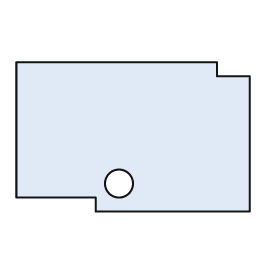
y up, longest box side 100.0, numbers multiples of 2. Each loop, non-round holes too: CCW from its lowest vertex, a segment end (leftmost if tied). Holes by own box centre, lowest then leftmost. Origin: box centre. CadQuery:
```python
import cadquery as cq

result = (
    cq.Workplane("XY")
    .moveTo(-16.0, -32.0)
    .lineTo(50.0, -32.0)
    .lineTo(50.0, 26.0)
    .lineTo(36.0, 26.0)
    .lineTo(36.0, 32.0)
    .lineTo(-50.0, 32.0)
    .lineTo(-50.0, -26.0)
    .lineTo(-16.0, -26.0)
    .close()
    .moveTo(-6.0, -20.0)
    .circle(6.0)
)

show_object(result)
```